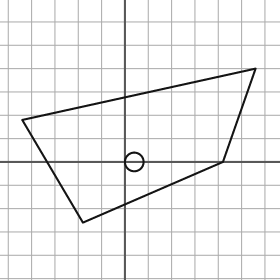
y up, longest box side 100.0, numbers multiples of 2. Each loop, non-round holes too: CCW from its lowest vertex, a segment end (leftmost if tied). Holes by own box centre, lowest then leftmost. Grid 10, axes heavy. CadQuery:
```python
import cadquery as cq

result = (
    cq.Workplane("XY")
    .moveTo(-18.0, -26.0)
    .lineTo(42.0, 0.0)
    .lineTo(56.0, 40.0)
    .lineTo(-44.0, 18.0)
    .close()
    .moveTo(4.0, 0.0)
    .circle(4.0)
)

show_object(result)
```